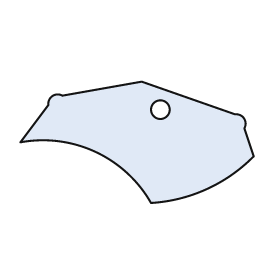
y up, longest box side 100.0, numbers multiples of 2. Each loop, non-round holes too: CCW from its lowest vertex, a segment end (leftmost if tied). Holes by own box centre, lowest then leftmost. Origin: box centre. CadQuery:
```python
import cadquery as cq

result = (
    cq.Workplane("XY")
    .moveTo(6.0, -26.0)
    .threePointArc((30.0, -20.0), (50.0, -6.0))
    .lineTo(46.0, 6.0)
    .threePointArc((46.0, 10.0), (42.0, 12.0))
    .lineTo(2.0, 26.0)
    .lineTo(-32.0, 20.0)
    .threePointArc((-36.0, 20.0), (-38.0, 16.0))
    .lineTo(-50.0, 0.0)
    .threePointArc((-18.0, -4.0), (6.0, -26.0))
    .close()
    .moveTo(10.0, 14.0)
    .circle(4.0)
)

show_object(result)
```